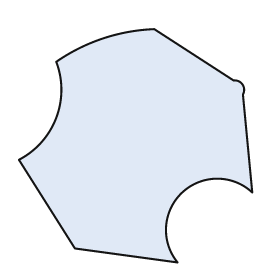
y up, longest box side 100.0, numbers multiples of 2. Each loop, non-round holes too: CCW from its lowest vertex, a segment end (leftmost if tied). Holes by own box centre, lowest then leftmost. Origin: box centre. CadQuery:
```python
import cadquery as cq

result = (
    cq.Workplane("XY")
    .moveTo(18.0, -50.0)
    .threePointArc((20.0, -20.0), (50.0, -20.0))
    .lineTo(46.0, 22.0)
    .threePointArc((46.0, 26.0), (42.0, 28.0))
    .lineTo(8.0, 50.0)
    .threePointArc((-14.0, 46.0), (-34.0, 36.0))
    .threePointArc((-34.0, 12.0), (-50.0, -6.0))
    .lineTo(-26.0, -44.0)
    .close()
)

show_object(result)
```